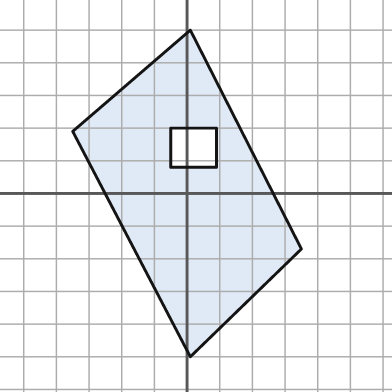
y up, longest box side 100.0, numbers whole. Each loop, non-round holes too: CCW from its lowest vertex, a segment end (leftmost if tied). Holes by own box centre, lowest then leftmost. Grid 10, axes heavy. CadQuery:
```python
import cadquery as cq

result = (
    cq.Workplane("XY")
    .moveTo(1.0, -50.0)
    .lineTo(35.0, -17.0)
    .lineTo(1.0, 50.0)
    .lineTo(-35.0, 19.0)
    .close()
    .moveTo(-5.0, 8.0)
    .lineTo(9.0, 8.0)
    .lineTo(9.0, 20.0)
    .lineTo(-5.0, 20.0)
    .close()
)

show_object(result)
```